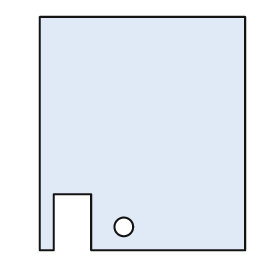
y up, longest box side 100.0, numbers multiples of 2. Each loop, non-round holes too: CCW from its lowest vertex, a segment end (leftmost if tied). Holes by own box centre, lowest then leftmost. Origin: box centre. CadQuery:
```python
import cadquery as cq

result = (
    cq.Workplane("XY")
    .moveTo(-44.0, -50.0)
    .lineTo(-38.0, -50.0)
    .lineTo(-38.0, -26.0)
    .lineTo(-22.0, -26.0)
    .lineTo(-22.0, -50.0)
    .lineTo(44.0, -50.0)
    .lineTo(44.0, 50.0)
    .lineTo(-44.0, 50.0)
    .close()
    .moveTo(-8.0, -40.0)
    .circle(4.0)
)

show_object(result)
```